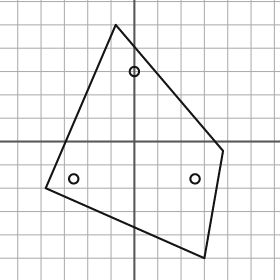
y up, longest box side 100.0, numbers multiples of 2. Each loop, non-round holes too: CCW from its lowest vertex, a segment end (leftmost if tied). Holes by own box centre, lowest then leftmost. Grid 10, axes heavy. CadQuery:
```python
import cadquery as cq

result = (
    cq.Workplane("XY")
    .moveTo(30.0, -50.0)
    .lineTo(38.0, -4.0)
    .lineTo(-8.0, 50.0)
    .lineTo(-38.0, -20.0)
    .close()
    .moveTo(-26.0, -16.0)
    .circle(2.0)
    .moveTo(26.0, -16.0)
    .circle(2.0)
    .moveTo(0.0, 30.0)
    .circle(2.0)
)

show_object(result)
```